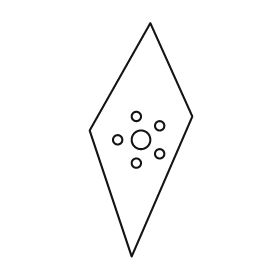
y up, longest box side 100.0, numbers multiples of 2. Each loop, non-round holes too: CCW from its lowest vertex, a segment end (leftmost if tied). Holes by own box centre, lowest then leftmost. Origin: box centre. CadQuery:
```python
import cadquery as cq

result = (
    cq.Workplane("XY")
    .moveTo(-4.0, -50.0)
    .lineTo(22.0, 10.0)
    .lineTo(4.0, 50.0)
    .lineTo(-22.0, 4.0)
    .close()
    .moveTo(-2.0, -10.0)
    .circle(2.0)
    .moveTo(8.0, -6.0)
    .circle(2.0)
    .moveTo(-10.0, 0.0)
    .circle(2.0)
    .moveTo(0.0, 0.0)
    .circle(4.0)
    .moveTo(8.0, 6.0)
    .circle(2.0)
    .moveTo(-2.0, 10.0)
    .circle(2.0)
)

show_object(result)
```